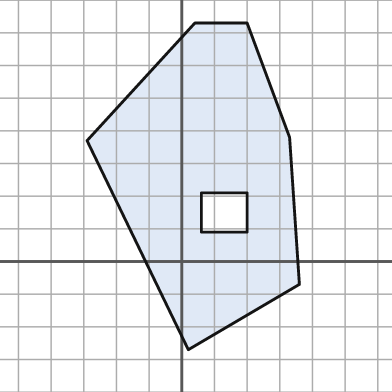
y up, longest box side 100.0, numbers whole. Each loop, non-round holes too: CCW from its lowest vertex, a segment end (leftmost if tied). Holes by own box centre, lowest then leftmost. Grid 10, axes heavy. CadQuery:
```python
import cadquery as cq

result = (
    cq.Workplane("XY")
    .moveTo(2.0, -27.0)
    .lineTo(36.0, -7.0)
    .lineTo(33.0, 38.0)
    .lineTo(20.0, 73.0)
    .lineTo(4.0, 73.0)
    .lineTo(-29.0, 37.0)
    .close()
    .moveTo(6.0, 9.0)
    .lineTo(20.0, 9.0)
    .lineTo(20.0, 21.0)
    .lineTo(6.0, 21.0)
    .close()
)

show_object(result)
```